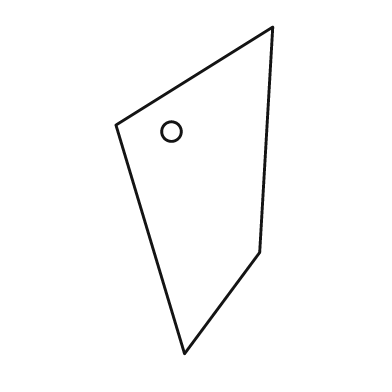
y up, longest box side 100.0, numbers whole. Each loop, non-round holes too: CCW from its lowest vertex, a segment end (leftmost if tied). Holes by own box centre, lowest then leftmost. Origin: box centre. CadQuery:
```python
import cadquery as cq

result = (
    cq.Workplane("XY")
    .moveTo(-3.0, -50.0)
    .lineTo(20.0, -19.0)
    .lineTo(24.0, 50.0)
    .lineTo(-24.0, 20.0)
    .close()
    .moveTo(-7.0, 18.0)
    .circle(3.0)
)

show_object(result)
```